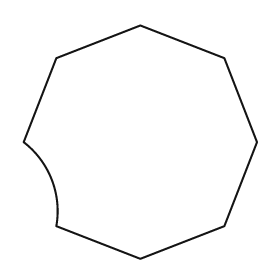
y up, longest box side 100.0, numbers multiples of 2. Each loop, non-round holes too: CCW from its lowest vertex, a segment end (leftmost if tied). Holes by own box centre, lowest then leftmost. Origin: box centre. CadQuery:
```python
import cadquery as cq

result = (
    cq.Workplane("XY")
    .moveTo(0.0, -50.0)
    .lineTo(36.0, -36.0)
    .lineTo(50.0, 0.0)
    .lineTo(36.0, 36.0)
    .lineTo(0.0, 50.0)
    .lineTo(-36.0, 36.0)
    .lineTo(-50.0, 0.0)
    .threePointArc((-38.0, -16.0), (-36.0, -36.0))
    .close()
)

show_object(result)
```